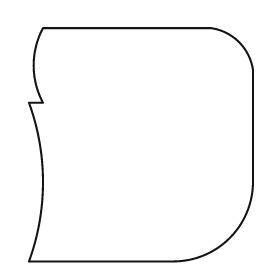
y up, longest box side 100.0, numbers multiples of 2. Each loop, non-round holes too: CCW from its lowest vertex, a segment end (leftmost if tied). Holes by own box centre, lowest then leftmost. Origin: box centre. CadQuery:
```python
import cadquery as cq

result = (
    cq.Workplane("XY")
    .moveTo(-48.0, -50.0)
    .lineTo(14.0, -50.0)
    .threePointArc((38.0, -40.0), (48.0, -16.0))
    .lineTo(48.0, 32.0)
    .threePointArc((42.0, 44.0), (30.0, 50.0))
    .lineTo(-42.0, 50.0)
    .threePointArc((-46.0, 34.0), (-42.0, 18.0))
    .lineTo(-48.0, 18.0)
    .threePointArc((-42.0, -16.0), (-48.0, -50.0))
    .close()
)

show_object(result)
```